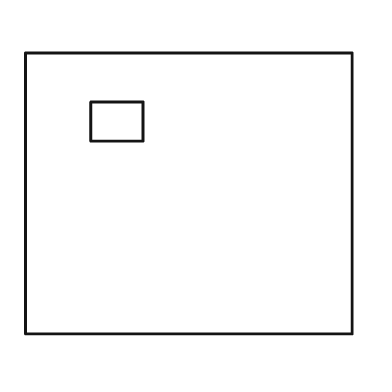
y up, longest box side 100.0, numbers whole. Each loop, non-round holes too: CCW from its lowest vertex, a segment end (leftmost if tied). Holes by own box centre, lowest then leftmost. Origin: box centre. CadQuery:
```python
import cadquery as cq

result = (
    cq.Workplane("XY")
    .moveTo(-50.0, -43.0)
    .lineTo(50.0, -43.0)
    .lineTo(50.0, 43.0)
    .lineTo(-50.0, 43.0)
    .close()
    .moveTo(-30.0, 16.0)
    .lineTo(-14.0, 16.0)
    .lineTo(-14.0, 28.0)
    .lineTo(-30.0, 28.0)
    .close()
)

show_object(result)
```